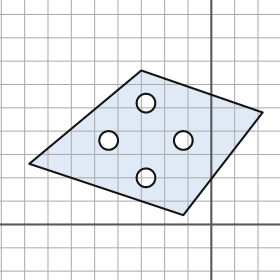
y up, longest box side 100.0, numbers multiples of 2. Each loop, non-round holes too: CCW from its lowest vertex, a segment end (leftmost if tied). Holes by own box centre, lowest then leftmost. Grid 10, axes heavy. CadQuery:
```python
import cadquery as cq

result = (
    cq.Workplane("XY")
    .moveTo(-12.0, 4.0)
    .lineTo(22.0, 48.0)
    .lineTo(-30.0, 66.0)
    .lineTo(-78.0, 26.0)
    .close()
    .moveTo(-28.0, 20.0)
    .circle(4.0)
    .moveTo(-44.0, 36.0)
    .circle(4.0)
    .moveTo(-12.0, 36.0)
    .circle(4.0)
    .moveTo(-28.0, 52.0)
    .circle(4.0)
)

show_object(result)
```